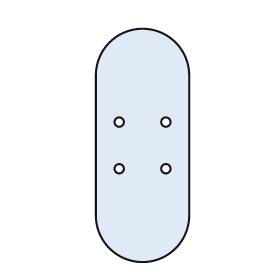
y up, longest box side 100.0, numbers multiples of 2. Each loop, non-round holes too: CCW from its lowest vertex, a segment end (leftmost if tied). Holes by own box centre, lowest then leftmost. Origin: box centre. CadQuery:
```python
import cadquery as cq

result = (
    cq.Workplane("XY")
    .moveTo(-20.0, -30.0)
    .threePointArc((0.0, -50.0), (20.0, -30.0))
    .lineTo(20.0, 30.0)
    .threePointArc((0.0, 50.0), (-20.0, 30.0))
    .close()
    .moveTo(-10.0, -10.0)
    .circle(2.0)
    .moveTo(10.0, -10.0)
    .circle(2.0)
    .moveTo(-10.0, 10.0)
    .circle(2.0)
    .moveTo(10.0, 10.0)
    .circle(2.0)
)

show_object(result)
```